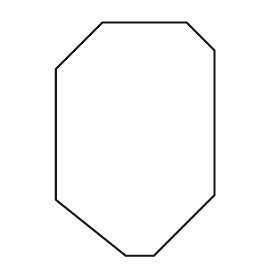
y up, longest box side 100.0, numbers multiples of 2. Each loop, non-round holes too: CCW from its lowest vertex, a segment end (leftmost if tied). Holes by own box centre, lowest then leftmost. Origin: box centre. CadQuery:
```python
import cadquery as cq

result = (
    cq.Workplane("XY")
    .moveTo(-4.0, -50.0)
    .lineTo(8.0, -50.0)
    .lineTo(34.0, -24.0)
    .lineTo(34.0, 38.0)
    .lineTo(22.0, 50.0)
    .lineTo(-14.0, 50.0)
    .lineTo(-34.0, 30.0)
    .lineTo(-34.0, -26.0)
    .close()
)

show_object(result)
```